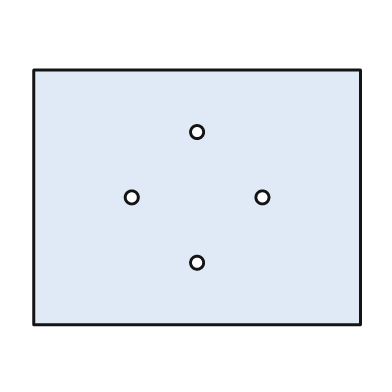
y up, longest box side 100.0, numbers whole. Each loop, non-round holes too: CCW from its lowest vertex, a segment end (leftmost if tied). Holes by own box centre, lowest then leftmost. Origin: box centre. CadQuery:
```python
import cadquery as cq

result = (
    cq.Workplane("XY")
    .moveTo(-50.0, -39.0)
    .lineTo(50.0, -39.0)
    .lineTo(50.0, 39.0)
    .lineTo(-50.0, 39.0)
    .close()
    .moveTo(0.0, -20.0)
    .circle(2.0)
    .moveTo(-20.0, 0.0)
    .circle(2.0)
    .moveTo(20.0, 0.0)
    .circle(2.0)
    .moveTo(0.0, 20.0)
    .circle(2.0)
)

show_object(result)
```